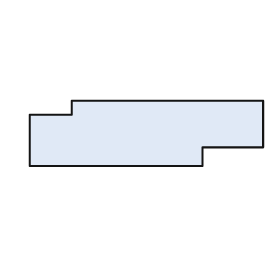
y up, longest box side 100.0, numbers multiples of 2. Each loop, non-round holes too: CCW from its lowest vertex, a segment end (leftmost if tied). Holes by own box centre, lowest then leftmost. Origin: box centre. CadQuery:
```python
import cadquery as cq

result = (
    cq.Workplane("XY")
    .moveTo(-50.0, -14.0)
    .lineTo(24.0, -14.0)
    .lineTo(24.0, -6.0)
    .lineTo(50.0, -6.0)
    .lineTo(50.0, 14.0)
    .lineTo(-32.0, 14.0)
    .lineTo(-32.0, 8.0)
    .lineTo(-50.0, 8.0)
    .close()
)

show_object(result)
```